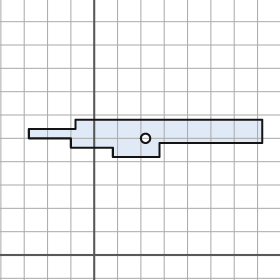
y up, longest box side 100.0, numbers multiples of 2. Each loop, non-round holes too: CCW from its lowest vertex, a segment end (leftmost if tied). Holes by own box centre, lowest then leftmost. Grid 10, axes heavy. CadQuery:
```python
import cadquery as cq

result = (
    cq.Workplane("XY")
    .moveTo(8.0, 42.0)
    .lineTo(28.0, 42.0)
    .lineTo(28.0, 48.0)
    .lineTo(72.0, 48.0)
    .lineTo(72.0, 58.0)
    .lineTo(-8.0, 58.0)
    .lineTo(-8.0, 54.0)
    .lineTo(-28.0, 54.0)
    .lineTo(-28.0, 50.0)
    .lineTo(-10.0, 50.0)
    .lineTo(-10.0, 46.0)
    .lineTo(8.0, 46.0)
    .close()
    .moveTo(22.0, 50.0)
    .circle(2.0)
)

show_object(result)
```